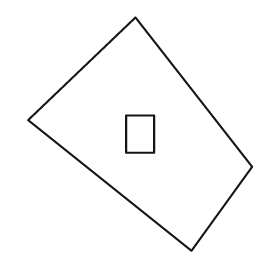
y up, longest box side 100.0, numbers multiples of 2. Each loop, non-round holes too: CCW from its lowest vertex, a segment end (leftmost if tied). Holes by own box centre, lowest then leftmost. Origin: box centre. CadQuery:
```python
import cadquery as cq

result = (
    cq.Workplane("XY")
    .moveTo(22.0, -50.0)
    .lineTo(48.0, -14.0)
    .lineTo(-2.0, 50.0)
    .lineTo(-48.0, 6.0)
    .close()
    .moveTo(-6.0, -8.0)
    .lineTo(6.0, -8.0)
    .lineTo(6.0, 8.0)
    .lineTo(-6.0, 8.0)
    .close()
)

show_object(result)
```